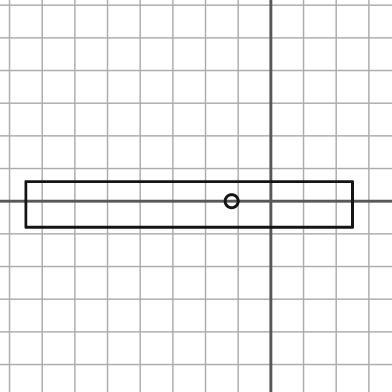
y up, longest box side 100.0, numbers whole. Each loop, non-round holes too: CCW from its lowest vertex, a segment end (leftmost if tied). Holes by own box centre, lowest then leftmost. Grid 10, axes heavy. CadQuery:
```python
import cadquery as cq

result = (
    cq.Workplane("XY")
    .moveTo(-75.0, -8.0)
    .lineTo(25.0, -8.0)
    .lineTo(25.0, 6.0)
    .lineTo(-75.0, 6.0)
    .close()
    .moveTo(-12.0, 0.0)
    .circle(2.0)
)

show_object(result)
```